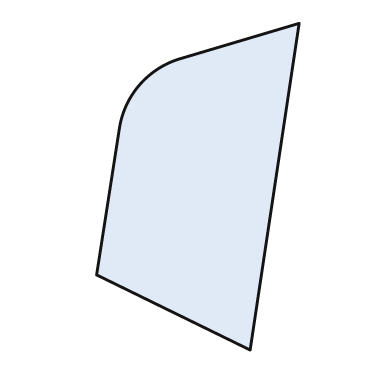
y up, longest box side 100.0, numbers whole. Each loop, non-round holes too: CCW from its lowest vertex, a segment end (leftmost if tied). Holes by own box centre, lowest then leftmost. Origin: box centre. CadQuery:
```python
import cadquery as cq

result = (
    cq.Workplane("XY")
    .moveTo(16.0, -50.0)
    .lineTo(31.0, 50.0)
    .lineTo(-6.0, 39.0)
    .threePointArc((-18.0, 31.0), (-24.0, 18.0))
    .lineTo(-31.0, -27.0)
    .close()
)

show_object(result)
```